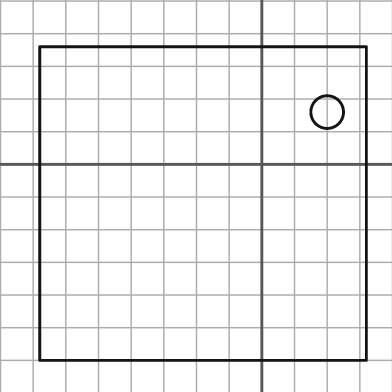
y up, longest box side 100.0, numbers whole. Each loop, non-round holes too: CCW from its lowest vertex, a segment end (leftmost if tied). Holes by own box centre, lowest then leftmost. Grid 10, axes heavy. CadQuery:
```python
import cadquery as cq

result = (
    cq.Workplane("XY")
    .moveTo(-68.0, -60.0)
    .lineTo(32.0, -60.0)
    .lineTo(32.0, 36.0)
    .lineTo(-68.0, 36.0)
    .close()
    .moveTo(20.0, 16.0)
    .circle(5.0)
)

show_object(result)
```